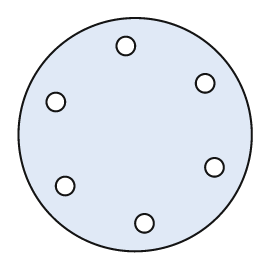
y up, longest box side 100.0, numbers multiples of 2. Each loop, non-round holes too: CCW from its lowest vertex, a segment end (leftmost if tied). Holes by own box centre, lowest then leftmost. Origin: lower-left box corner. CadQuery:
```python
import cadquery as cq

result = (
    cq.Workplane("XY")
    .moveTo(50.0, 50.0)
    .circle(50.0)
    .moveTo(54.0, 12.0)
    .circle(4.0)
    .moveTo(20.0, 28.0)
    .circle(4.0)
    .moveTo(84.0, 36.0)
    .circle(4.0)
    .moveTo(16.0, 64.0)
    .circle(4.0)
    .moveTo(80.0, 72.0)
    .circle(4.0)
    .moveTo(46.0, 88.0)
    .circle(4.0)
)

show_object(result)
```